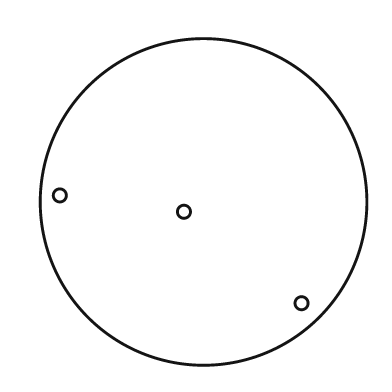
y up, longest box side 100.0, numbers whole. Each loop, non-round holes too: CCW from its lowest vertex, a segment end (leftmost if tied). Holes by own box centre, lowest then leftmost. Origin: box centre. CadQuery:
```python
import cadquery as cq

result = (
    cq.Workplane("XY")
    .moveTo(0.0, 0.0)
    .circle(50.0)
    .moveTo(30.0, -31.0)
    .circle(2.0)
    .moveTo(-6.0, -3.0)
    .circle(2.0)
    .moveTo(-44.0, 2.0)
    .circle(2.0)
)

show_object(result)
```